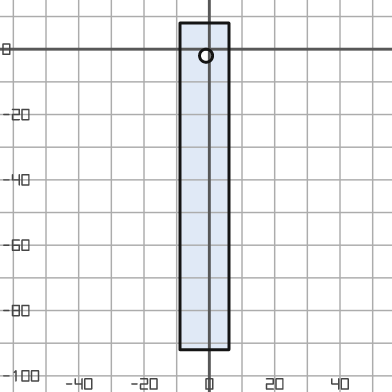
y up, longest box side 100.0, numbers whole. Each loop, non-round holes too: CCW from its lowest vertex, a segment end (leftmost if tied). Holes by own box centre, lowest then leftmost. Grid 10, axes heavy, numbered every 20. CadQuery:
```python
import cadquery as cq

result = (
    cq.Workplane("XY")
    .moveTo(-9.0, -92.0)
    .lineTo(6.0, -92.0)
    .lineTo(6.0, 8.0)
    .lineTo(-9.0, 8.0)
    .close()
    .moveTo(-1.0, -2.0)
    .circle(2.0)
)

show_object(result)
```